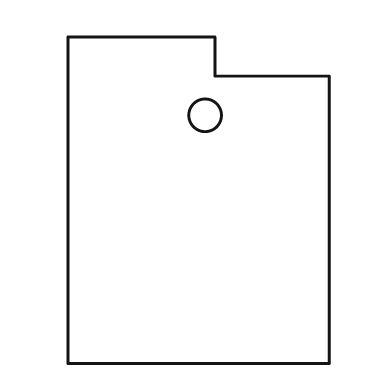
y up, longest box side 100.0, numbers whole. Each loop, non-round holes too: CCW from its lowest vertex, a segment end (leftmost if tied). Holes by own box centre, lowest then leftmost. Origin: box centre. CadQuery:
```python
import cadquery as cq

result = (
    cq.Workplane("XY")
    .moveTo(-40.0, -50.0)
    .lineTo(40.0, -50.0)
    .lineTo(40.0, 38.0)
    .lineTo(5.0, 38.0)
    .lineTo(5.0, 50.0)
    .lineTo(-40.0, 50.0)
    .close()
    .moveTo(2.0, 26.0)
    .circle(5.0)
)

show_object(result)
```